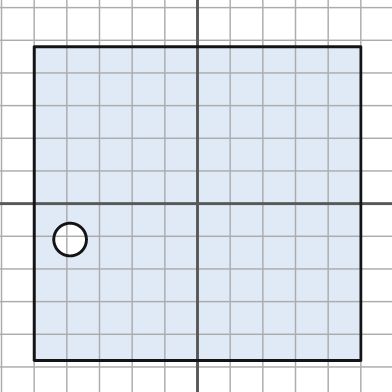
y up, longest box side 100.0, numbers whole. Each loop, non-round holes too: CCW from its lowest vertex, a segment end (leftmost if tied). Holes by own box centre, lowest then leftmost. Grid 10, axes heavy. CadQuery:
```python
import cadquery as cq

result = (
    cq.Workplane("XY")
    .moveTo(-50.0, -48.0)
    .lineTo(50.0, -48.0)
    .lineTo(50.0, 48.0)
    .lineTo(-50.0, 48.0)
    .close()
    .moveTo(-39.0, -11.0)
    .circle(5.0)
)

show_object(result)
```